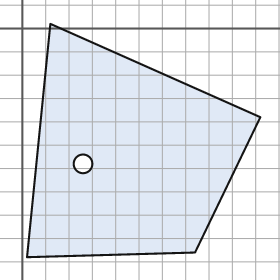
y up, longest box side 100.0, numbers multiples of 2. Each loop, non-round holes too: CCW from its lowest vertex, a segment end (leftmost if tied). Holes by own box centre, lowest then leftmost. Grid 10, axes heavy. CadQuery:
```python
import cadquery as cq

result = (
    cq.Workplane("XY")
    .moveTo(2.0, -98.0)
    .lineTo(74.0, -96.0)
    .lineTo(102.0, -38.0)
    .lineTo(12.0, 2.0)
    .close()
    .moveTo(26.0, -58.0)
    .circle(4.0)
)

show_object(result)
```